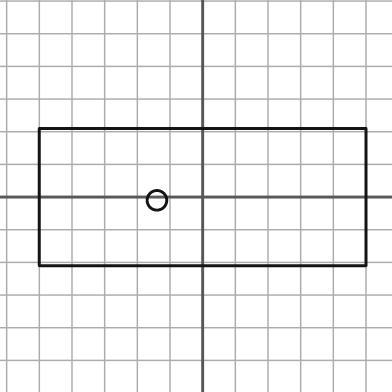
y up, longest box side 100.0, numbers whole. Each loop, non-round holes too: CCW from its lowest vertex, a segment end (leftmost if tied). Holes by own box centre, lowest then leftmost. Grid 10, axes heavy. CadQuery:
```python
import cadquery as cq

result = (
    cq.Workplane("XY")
    .moveTo(-50.0, -21.0)
    .lineTo(50.0, -21.0)
    .lineTo(50.0, 21.0)
    .lineTo(-50.0, 21.0)
    .close()
    .moveTo(-14.0, -1.0)
    .circle(3.0)
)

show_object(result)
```